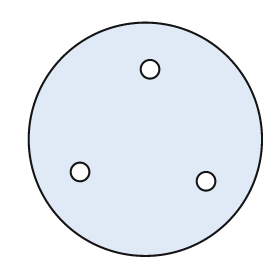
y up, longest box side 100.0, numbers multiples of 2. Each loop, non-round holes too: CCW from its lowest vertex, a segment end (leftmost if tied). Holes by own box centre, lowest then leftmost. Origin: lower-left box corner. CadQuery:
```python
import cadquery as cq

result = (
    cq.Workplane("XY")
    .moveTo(50.0, 50.0)
    .circle(50.0)
    .moveTo(76.0, 32.0)
    .circle(4.0)
    .moveTo(22.0, 36.0)
    .circle(4.0)
    .moveTo(52.0, 80.0)
    .circle(4.0)
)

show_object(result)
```